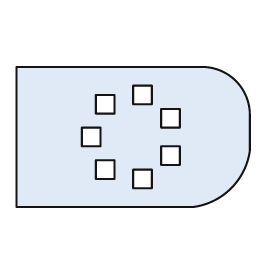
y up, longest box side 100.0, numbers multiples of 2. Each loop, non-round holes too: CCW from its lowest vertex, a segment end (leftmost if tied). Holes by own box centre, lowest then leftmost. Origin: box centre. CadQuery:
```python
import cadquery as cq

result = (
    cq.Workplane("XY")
    .moveTo(-50.0, -30.0)
    .lineTo(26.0, -30.0)
    .threePointArc((42.0, -22.0), (50.0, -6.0))
    .lineTo(50.0, 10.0)
    .threePointArc((44.0, 24.0), (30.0, 30.0))
    .lineTo(-50.0, 30.0)
    .close()
    .moveTo(0.0, -22.0)
    .lineTo(8.0, -22.0)
    .lineTo(8.0, -14.0)
    .lineTo(0.0, -14.0)
    .close()
    .moveTo(-16.0, -18.0)
    .lineTo(-8.0, -18.0)
    .lineTo(-8.0, -10.0)
    .lineTo(-16.0, -10.0)
    .close()
    .moveTo(12.0, -12.0)
    .lineTo(20.0, -12.0)
    .lineTo(20.0, -4.0)
    .lineTo(12.0, -4.0)
    .close()
    .moveTo(-22.0, -4.0)
    .lineTo(-14.0, -4.0)
    .lineTo(-14.0, 4.0)
    .lineTo(-22.0, 4.0)
    .close()
    .moveTo(12.0, 4.0)
    .lineTo(20.0, 4.0)
    .lineTo(20.0, 12.0)
    .lineTo(12.0, 12.0)
    .close()
    .moveTo(-16.0, 10.0)
    .lineTo(-8.0, 10.0)
    .lineTo(-8.0, 18.0)
    .lineTo(-16.0, 18.0)
    .close()
    .moveTo(0.0, 14.0)
    .lineTo(8.0, 14.0)
    .lineTo(8.0, 22.0)
    .lineTo(0.0, 22.0)
    .close()
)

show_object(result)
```